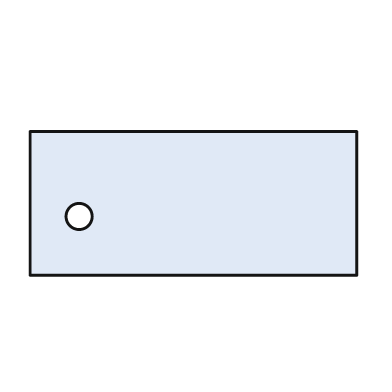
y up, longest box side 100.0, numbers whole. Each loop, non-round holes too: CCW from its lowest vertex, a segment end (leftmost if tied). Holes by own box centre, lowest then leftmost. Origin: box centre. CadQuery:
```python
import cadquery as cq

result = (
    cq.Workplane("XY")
    .moveTo(-50.0, -22.0)
    .lineTo(50.0, -22.0)
    .lineTo(50.0, 22.0)
    .lineTo(-50.0, 22.0)
    .close()
    .moveTo(-35.0, -4.0)
    .circle(4.0)
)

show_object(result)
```